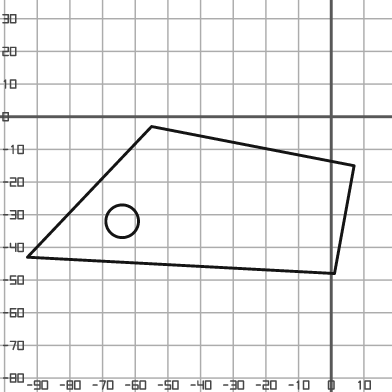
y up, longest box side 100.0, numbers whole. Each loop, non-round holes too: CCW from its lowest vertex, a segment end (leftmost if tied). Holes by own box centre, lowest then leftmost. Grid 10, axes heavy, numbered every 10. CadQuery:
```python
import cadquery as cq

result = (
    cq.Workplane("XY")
    .moveTo(1.0, -48.0)
    .lineTo(7.0, -15.0)
    .lineTo(-55.0, -3.0)
    .lineTo(-93.0, -43.0)
    .close()
    .moveTo(-64.0, -32.0)
    .circle(5.0)
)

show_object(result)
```